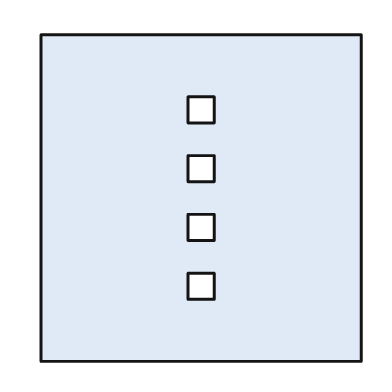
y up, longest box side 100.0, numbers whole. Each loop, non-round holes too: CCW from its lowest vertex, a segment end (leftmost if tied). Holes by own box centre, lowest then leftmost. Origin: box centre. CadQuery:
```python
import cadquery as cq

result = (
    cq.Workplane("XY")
    .moveTo(-49.0, -50.0)
    .lineTo(49.0, -50.0)
    .lineTo(49.0, 50.0)
    .lineTo(-49.0, 50.0)
    .close()
    .moveTo(-4.0, -31.0)
    .lineTo(4.0, -31.0)
    .lineTo(4.0, -23.0)
    .lineTo(-4.0, -23.0)
    .close()
    .moveTo(-4.0, -13.0)
    .lineTo(4.0, -13.0)
    .lineTo(4.0, -5.0)
    .lineTo(-4.0, -5.0)
    .close()
    .moveTo(-4.0, 5.0)
    .lineTo(4.0, 5.0)
    .lineTo(4.0, 13.0)
    .lineTo(-4.0, 13.0)
    .close()
    .moveTo(-4.0, 23.0)
    .lineTo(4.0, 23.0)
    .lineTo(4.0, 31.0)
    .lineTo(-4.0, 31.0)
    .close()
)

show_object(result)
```